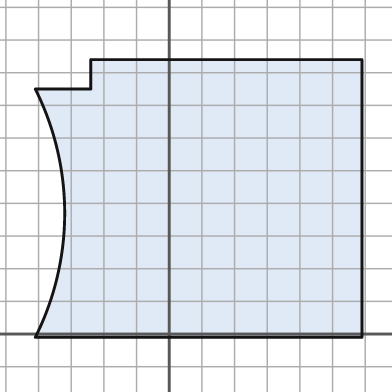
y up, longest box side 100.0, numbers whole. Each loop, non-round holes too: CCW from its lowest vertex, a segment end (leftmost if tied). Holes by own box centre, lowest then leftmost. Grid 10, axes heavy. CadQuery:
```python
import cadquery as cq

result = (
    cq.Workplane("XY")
    .moveTo(-41.0, -1.0)
    .lineTo(59.0, -1.0)
    .lineTo(59.0, 84.0)
    .lineTo(-24.0, 84.0)
    .lineTo(-24.0, 75.0)
    .lineTo(-41.0, 75.0)
    .threePointArc((-32.0, 37.0), (-41.0, -1.0))
    .close()
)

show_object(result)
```